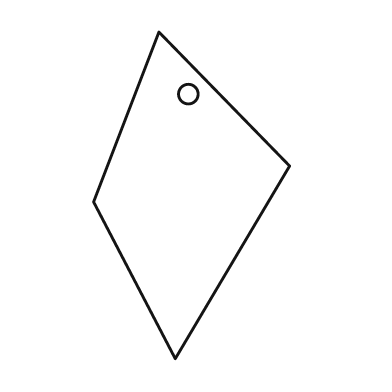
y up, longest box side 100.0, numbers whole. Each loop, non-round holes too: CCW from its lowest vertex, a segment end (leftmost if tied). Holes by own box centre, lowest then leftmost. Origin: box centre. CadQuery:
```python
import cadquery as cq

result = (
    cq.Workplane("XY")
    .moveTo(-5.0, -50.0)
    .lineTo(30.0, 9.0)
    .lineTo(-10.0, 50.0)
    .lineTo(-30.0, -2.0)
    .close()
    .moveTo(-1.0, 31.0)
    .circle(3.0)
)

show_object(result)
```